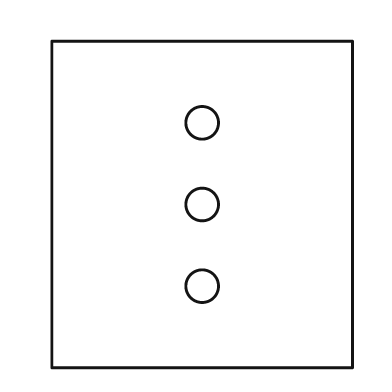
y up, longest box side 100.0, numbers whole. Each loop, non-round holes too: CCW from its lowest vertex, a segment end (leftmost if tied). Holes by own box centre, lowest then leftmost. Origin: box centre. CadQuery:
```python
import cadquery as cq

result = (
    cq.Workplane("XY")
    .moveTo(-46.0, -50.0)
    .lineTo(46.0, -50.0)
    .lineTo(46.0, 50.0)
    .lineTo(-46.0, 50.0)
    .close()
    .moveTo(0.0, -25.0)
    .circle(5.0)
    .moveTo(0.0, 0.0)
    .circle(5.0)
    .moveTo(0.0, 25.0)
    .circle(5.0)
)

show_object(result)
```